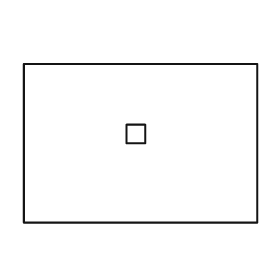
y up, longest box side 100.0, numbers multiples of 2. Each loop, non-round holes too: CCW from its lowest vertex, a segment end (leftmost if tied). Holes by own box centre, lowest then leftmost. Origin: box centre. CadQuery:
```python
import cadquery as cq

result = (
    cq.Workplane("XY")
    .moveTo(-50.0, -34.0)
    .lineTo(50.0, -34.0)
    .lineTo(50.0, 34.0)
    .lineTo(-50.0, 34.0)
    .close()
    .moveTo(-6.0, 0.0)
    .lineTo(2.0, 0.0)
    .lineTo(2.0, 8.0)
    .lineTo(-6.0, 8.0)
    .close()
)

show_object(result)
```